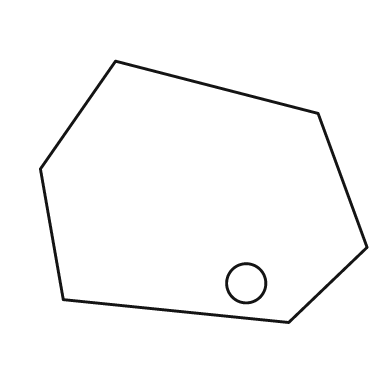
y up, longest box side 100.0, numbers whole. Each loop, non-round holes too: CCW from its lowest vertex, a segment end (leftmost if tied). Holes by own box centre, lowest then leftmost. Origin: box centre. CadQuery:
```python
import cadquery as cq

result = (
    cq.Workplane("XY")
    .moveTo(26.0, -40.0)
    .lineTo(50.0, -17.0)
    .lineTo(35.0, 24.0)
    .lineTo(-27.0, 40.0)
    .lineTo(-50.0, 7.0)
    .lineTo(-43.0, -33.0)
    .close()
    .moveTo(13.0, -28.0)
    .circle(6.0)
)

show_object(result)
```